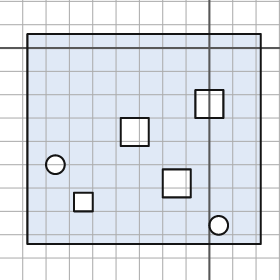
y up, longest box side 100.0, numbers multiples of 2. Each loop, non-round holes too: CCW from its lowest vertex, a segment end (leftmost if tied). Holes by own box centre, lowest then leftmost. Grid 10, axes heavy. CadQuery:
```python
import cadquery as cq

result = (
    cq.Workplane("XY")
    .moveTo(-78.0, -84.0)
    .lineTo(22.0, -84.0)
    .lineTo(22.0, 6.0)
    .lineTo(-78.0, 6.0)
    .close()
    .moveTo(4.0, -76.0)
    .circle(4.0)
    .moveTo(-58.0, -70.0)
    .lineTo(-50.0, -70.0)
    .lineTo(-50.0, -62.0)
    .lineTo(-58.0, -62.0)
    .close()
    .moveTo(-20.0, -64.0)
    .lineTo(-8.0, -64.0)
    .lineTo(-8.0, -52.0)
    .lineTo(-20.0, -52.0)
    .close()
    .moveTo(-66.0, -50.0)
    .circle(4.0)
    .moveTo(-38.0, -42.0)
    .lineTo(-26.0, -42.0)
    .lineTo(-26.0, -30.0)
    .lineTo(-38.0, -30.0)
    .close()
    .moveTo(-6.0, -30.0)
    .lineTo(6.0, -30.0)
    .lineTo(6.0, -18.0)
    .lineTo(-6.0, -18.0)
    .close()
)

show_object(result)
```